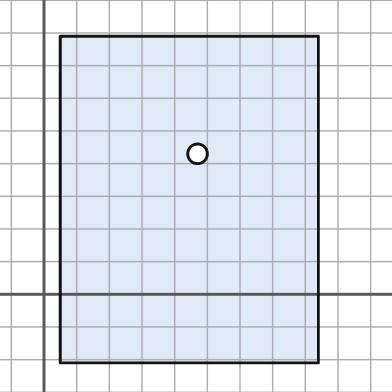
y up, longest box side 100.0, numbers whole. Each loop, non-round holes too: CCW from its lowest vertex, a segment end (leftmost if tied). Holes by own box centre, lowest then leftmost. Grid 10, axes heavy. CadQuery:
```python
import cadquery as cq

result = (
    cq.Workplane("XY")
    .moveTo(5.0, -21.0)
    .lineTo(84.0, -21.0)
    .lineTo(84.0, 79.0)
    .lineTo(5.0, 79.0)
    .close()
    .moveTo(47.0, 43.0)
    .circle(3.0)
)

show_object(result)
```